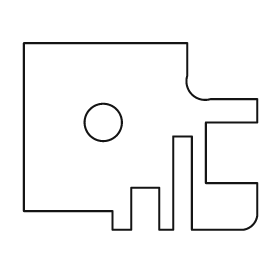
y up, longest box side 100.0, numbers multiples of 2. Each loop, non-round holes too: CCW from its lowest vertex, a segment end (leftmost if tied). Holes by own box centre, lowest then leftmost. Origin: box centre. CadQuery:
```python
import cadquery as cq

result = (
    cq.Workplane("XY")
    .moveTo(-12.0, -40.0)
    .lineTo(-4.0, -40.0)
    .lineTo(-4.0, -22.0)
    .lineTo(8.0, -22.0)
    .lineTo(8.0, -40.0)
    .lineTo(14.0, -40.0)
    .lineTo(14.0, 0.0)
    .lineTo(22.0, 0.0)
    .lineTo(22.0, -40.0)
    .lineTo(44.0, -40.0)
    .threePointArc((48.0, -38.0), (50.0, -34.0))
    .lineTo(50.0, -20.0)
    .lineTo(28.0, -20.0)
    .lineTo(28.0, 6.0)
    .lineTo(50.0, 6.0)
    .lineTo(50.0, 16.0)
    .lineTo(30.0, 16.0)
    .threePointArc((22.0, 18.0), (20.0, 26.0))
    .lineTo(20.0, 40.0)
    .lineTo(-50.0, 40.0)
    .lineTo(-50.0, -32.0)
    .lineTo(-12.0, -32.0)
    .close()
    .moveTo(-16.0, 6.0)
    .circle(8.0)
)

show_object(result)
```